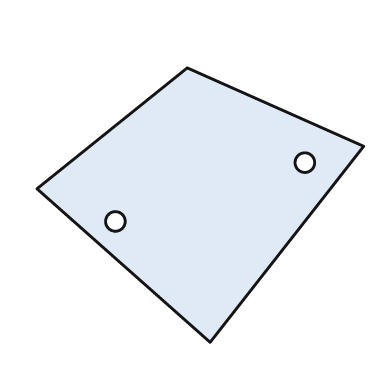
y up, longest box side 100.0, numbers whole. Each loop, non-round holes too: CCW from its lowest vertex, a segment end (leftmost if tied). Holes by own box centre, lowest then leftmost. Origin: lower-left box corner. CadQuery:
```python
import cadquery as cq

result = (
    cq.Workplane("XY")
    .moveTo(53.0, 0.0)
    .lineTo(100.0, 60.0)
    .lineTo(46.0, 84.0)
    .lineTo(0.0, 47.0)
    .close()
    .moveTo(24.0, 37.0)
    .circle(3.0)
    .moveTo(82.0, 55.0)
    .circle(3.0)
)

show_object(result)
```